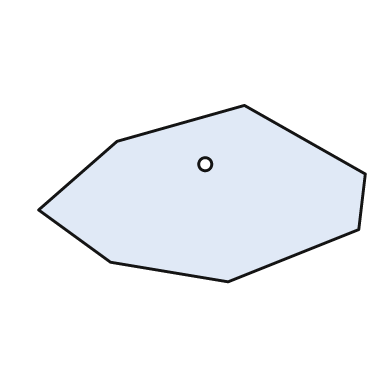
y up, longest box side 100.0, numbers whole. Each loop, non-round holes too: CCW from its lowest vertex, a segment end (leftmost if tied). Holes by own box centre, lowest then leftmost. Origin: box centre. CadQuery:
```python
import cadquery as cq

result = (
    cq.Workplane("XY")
    .moveTo(8.0, -27.0)
    .lineTo(48.0, -11.0)
    .lineTo(50.0, 6.0)
    .lineTo(13.0, 27.0)
    .lineTo(-26.0, 16.0)
    .lineTo(-50.0, -5.0)
    .lineTo(-28.0, -21.0)
    .close()
    .moveTo(1.0, 9.0)
    .circle(2.0)
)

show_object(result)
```